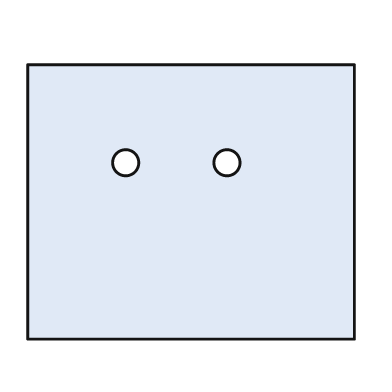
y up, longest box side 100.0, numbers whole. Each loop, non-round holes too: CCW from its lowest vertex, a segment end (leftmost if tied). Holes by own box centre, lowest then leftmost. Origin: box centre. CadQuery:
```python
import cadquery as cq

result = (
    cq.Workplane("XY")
    .moveTo(-50.0, -42.0)
    .lineTo(50.0, -42.0)
    .lineTo(50.0, 42.0)
    .lineTo(-50.0, 42.0)
    .close()
    .moveTo(-20.0, 12.0)
    .circle(4.0)
    .moveTo(11.0, 12.0)
    .circle(4.0)
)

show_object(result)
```